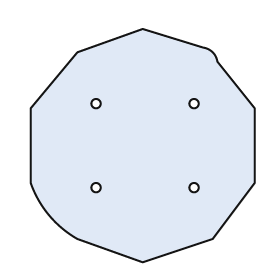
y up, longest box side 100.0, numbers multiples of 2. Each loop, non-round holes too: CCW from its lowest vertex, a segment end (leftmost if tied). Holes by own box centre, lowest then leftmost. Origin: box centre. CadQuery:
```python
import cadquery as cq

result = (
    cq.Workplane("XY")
    .moveTo(0.0, -50.0)
    .lineTo(30.0, -40.0)
    .lineTo(48.0, -16.0)
    .lineTo(48.0, 16.0)
    .lineTo(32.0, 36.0)
    .threePointArc((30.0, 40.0), (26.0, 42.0))
    .lineTo(0.0, 50.0)
    .lineTo(-28.0, 40.0)
    .lineTo(-48.0, 16.0)
    .lineTo(-48.0, -16.0)
    .threePointArc((-40.0, -30.0), (-28.0, -40.0))
    .close()
    .moveTo(-20.0, -18.0)
    .circle(2.0)
    .moveTo(22.0, -18.0)
    .circle(2.0)
    .moveTo(-20.0, 18.0)
    .circle(2.0)
    .moveTo(22.0, 18.0)
    .circle(2.0)
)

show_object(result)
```